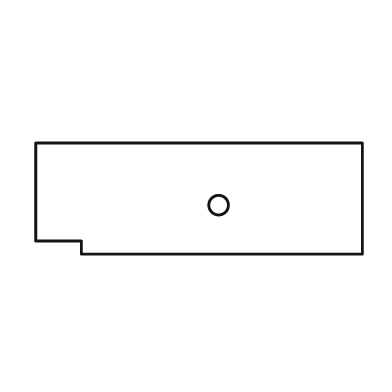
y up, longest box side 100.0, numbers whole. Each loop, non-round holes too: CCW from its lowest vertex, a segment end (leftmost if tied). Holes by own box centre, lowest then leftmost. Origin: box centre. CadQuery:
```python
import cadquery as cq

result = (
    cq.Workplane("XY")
    .moveTo(-36.0, -17.0)
    .lineTo(50.0, -17.0)
    .lineTo(50.0, 17.0)
    .lineTo(-50.0, 17.0)
    .lineTo(-50.0, -13.0)
    .lineTo(-36.0, -13.0)
    .close()
    .moveTo(6.0, -2.0)
    .circle(3.0)
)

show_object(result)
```